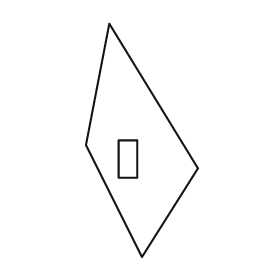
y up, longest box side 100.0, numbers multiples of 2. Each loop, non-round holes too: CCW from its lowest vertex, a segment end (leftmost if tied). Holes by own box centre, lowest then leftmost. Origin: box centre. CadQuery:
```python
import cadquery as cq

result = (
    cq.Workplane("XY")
    .moveTo(0.0, -50.0)
    .lineTo(24.0, -12.0)
    .lineTo(-14.0, 50.0)
    .lineTo(-24.0, -2.0)
    .close()
    .moveTo(-10.0, -16.0)
    .lineTo(-2.0, -16.0)
    .lineTo(-2.0, 0.0)
    .lineTo(-10.0, 0.0)
    .close()
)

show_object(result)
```